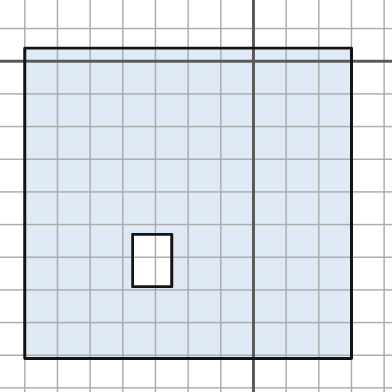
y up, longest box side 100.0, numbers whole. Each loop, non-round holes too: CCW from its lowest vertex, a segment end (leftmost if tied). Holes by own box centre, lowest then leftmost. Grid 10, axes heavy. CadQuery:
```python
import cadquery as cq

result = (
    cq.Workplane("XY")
    .moveTo(-70.0, -91.0)
    .lineTo(30.0, -91.0)
    .lineTo(30.0, 4.0)
    .lineTo(-70.0, 4.0)
    .close()
    .moveTo(-37.0, -69.0)
    .lineTo(-25.0, -69.0)
    .lineTo(-25.0, -53.0)
    .lineTo(-37.0, -53.0)
    .close()
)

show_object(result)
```